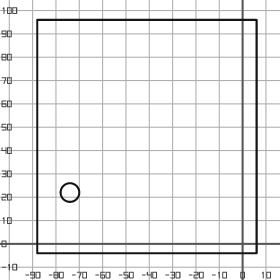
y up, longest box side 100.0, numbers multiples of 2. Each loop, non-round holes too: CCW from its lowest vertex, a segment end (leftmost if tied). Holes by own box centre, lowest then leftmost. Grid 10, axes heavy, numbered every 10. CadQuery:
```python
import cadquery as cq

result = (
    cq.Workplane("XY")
    .moveTo(-88.0, -4.0)
    .lineTo(6.0, -4.0)
    .lineTo(6.0, 96.0)
    .lineTo(-88.0, 96.0)
    .close()
    .moveTo(-74.0, 22.0)
    .circle(4.0)
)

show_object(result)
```